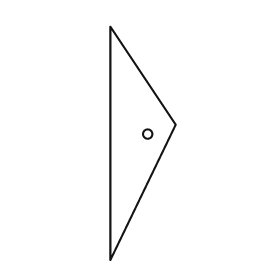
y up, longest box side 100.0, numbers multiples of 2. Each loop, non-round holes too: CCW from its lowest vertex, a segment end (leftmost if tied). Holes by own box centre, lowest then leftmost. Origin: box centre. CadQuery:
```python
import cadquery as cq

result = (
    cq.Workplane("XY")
    .moveTo(-14.0, -50.0)
    .lineTo(14.0, 8.0)
    .lineTo(-14.0, 50.0)
    .close()
    .moveTo(2.0, 4.0)
    .circle(2.0)
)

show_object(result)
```